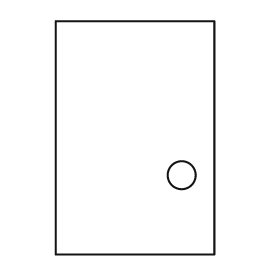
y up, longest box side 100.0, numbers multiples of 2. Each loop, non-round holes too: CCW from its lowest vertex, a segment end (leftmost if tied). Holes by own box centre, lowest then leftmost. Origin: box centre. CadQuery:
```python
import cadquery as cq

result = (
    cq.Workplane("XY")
    .moveTo(-34.0, -50.0)
    .lineTo(34.0, -50.0)
    .lineTo(34.0, 50.0)
    .lineTo(-34.0, 50.0)
    .close()
    .moveTo(20.0, -16.0)
    .circle(6.0)
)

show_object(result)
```